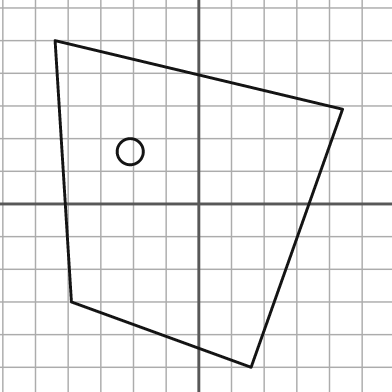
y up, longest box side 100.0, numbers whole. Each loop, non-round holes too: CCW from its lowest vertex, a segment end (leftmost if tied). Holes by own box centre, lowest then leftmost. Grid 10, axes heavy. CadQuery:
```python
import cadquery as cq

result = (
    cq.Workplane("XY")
    .moveTo(16.0, -50.0)
    .lineTo(44.0, 29.0)
    .lineTo(-44.0, 50.0)
    .lineTo(-39.0, -30.0)
    .close()
    .moveTo(-21.0, 16.0)
    .circle(4.0)
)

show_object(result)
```